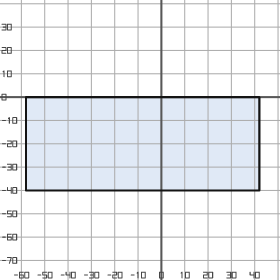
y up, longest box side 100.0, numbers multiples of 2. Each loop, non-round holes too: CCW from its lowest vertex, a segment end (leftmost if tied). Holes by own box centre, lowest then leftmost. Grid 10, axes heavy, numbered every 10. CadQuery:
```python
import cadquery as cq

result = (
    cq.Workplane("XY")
    .moveTo(-58.0, -40.0)
    .lineTo(42.0, -40.0)
    .lineTo(42.0, 0.0)
    .lineTo(-58.0, 0.0)
    .close()
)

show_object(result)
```